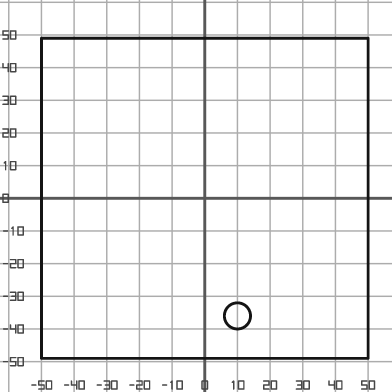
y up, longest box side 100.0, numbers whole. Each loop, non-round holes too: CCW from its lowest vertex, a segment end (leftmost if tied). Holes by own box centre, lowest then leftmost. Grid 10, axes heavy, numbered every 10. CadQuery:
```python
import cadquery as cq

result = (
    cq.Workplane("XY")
    .moveTo(-50.0, -49.0)
    .lineTo(50.0, -49.0)
    .lineTo(50.0, 49.0)
    .lineTo(-50.0, 49.0)
    .close()
    .moveTo(10.0, -36.0)
    .circle(4.0)
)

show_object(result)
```